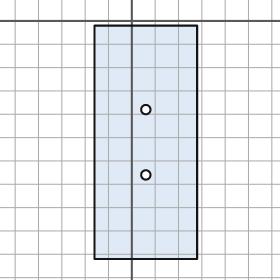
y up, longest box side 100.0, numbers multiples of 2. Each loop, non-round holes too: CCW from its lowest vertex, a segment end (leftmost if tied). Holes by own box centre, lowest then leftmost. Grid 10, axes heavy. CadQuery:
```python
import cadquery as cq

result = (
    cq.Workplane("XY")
    .moveTo(-16.0, -102.0)
    .lineTo(28.0, -102.0)
    .lineTo(28.0, -2.0)
    .lineTo(-16.0, -2.0)
    .close()
    .moveTo(6.0, -66.0)
    .circle(2.0)
    .moveTo(6.0, -38.0)
    .circle(2.0)
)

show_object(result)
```